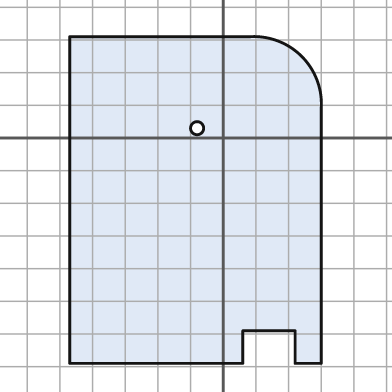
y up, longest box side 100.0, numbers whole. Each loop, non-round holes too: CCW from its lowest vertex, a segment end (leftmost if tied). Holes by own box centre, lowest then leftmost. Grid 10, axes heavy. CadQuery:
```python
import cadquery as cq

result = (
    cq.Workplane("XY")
    .moveTo(-47.0, -69.0)
    .lineTo(6.0, -69.0)
    .lineTo(6.0, -59.0)
    .lineTo(22.0, -59.0)
    .lineTo(22.0, -69.0)
    .lineTo(30.0, -69.0)
    .lineTo(30.0, 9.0)
    .threePointArc((24.0, 25.0), (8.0, 31.0))
    .lineTo(-47.0, 31.0)
    .close()
    .moveTo(-8.0, 3.0)
    .circle(2.0)
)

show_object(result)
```